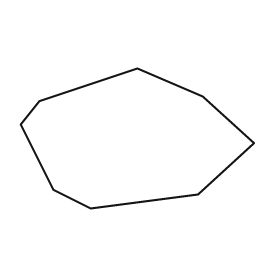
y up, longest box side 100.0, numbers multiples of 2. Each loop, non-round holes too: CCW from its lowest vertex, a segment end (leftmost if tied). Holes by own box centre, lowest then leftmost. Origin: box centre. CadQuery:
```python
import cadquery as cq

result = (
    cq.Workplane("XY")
    .moveTo(-20.0, -30.0)
    .lineTo(26.0, -24.0)
    .lineTo(50.0, -2.0)
    .lineTo(28.0, 18.0)
    .lineTo(0.0, 30.0)
    .lineTo(-42.0, 16.0)
    .lineTo(-50.0, 6.0)
    .lineTo(-36.0, -22.0)
    .close()
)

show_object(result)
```